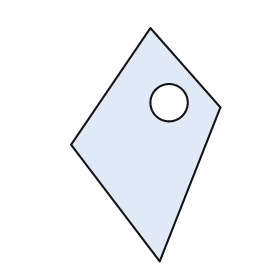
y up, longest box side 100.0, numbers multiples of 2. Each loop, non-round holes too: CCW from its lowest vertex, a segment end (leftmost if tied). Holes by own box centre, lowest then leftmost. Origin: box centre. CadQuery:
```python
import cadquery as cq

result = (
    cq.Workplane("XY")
    .moveTo(6.0, -50.0)
    .lineTo(32.0, 16.0)
    .lineTo(2.0, 50.0)
    .lineTo(-32.0, 0.0)
    .close()
    .moveTo(10.0, 18.0)
    .circle(8.0)
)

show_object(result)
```